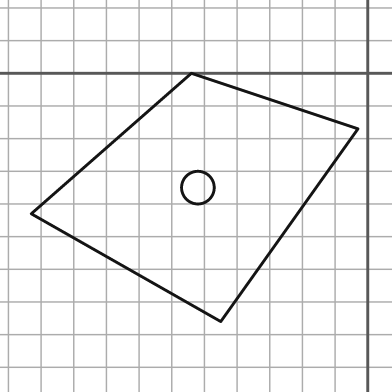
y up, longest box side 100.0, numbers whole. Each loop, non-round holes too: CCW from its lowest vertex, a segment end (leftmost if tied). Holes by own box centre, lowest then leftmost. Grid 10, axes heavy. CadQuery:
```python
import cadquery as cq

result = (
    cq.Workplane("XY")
    .moveTo(-45.0, -76.0)
    .lineTo(-3.0, -17.0)
    .lineTo(-54.0, 0.0)
    .lineTo(-103.0, -43.0)
    .close()
    .moveTo(-52.0, -35.0)
    .circle(5.0)
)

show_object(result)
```